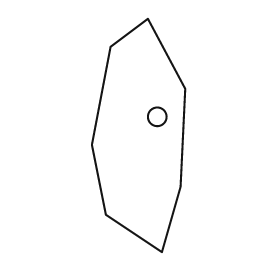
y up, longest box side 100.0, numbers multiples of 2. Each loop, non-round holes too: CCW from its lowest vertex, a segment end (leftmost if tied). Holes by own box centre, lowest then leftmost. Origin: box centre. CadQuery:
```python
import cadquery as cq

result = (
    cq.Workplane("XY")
    .moveTo(10.0, -50.0)
    .lineTo(18.0, -22.0)
    .lineTo(20.0, 20.0)
    .lineTo(4.0, 50.0)
    .lineTo(-12.0, 38.0)
    .lineTo(-20.0, -4.0)
    .lineTo(-14.0, -34.0)
    .close()
    .moveTo(8.0, 8.0)
    .circle(4.0)
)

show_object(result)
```